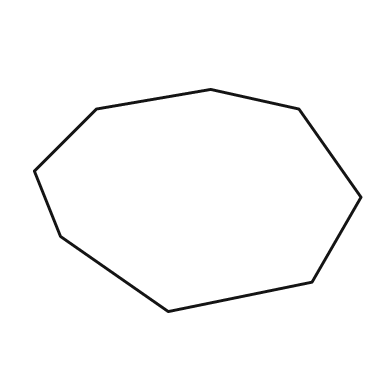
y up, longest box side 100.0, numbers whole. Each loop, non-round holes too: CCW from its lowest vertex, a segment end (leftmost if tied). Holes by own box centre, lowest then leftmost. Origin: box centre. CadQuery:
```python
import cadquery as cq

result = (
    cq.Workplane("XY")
    .moveTo(-9.0, -34.0)
    .lineTo(35.0, -25.0)
    .lineTo(50.0, 1.0)
    .lineTo(31.0, 28.0)
    .lineTo(4.0, 34.0)
    .lineTo(-31.0, 28.0)
    .lineTo(-50.0, 9.0)
    .lineTo(-42.0, -11.0)
    .close()
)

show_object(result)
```